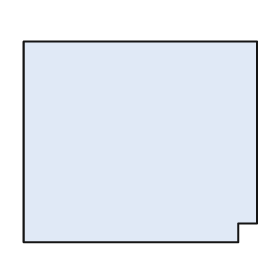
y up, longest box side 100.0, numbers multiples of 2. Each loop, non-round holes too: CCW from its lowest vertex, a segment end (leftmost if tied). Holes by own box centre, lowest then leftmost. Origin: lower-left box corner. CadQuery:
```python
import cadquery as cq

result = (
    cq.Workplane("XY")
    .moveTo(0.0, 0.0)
    .lineTo(92.0, 0.0)
    .lineTo(92.0, 8.0)
    .lineTo(100.0, 8.0)
    .lineTo(100.0, 86.0)
    .lineTo(0.0, 86.0)
    .close()
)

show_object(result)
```